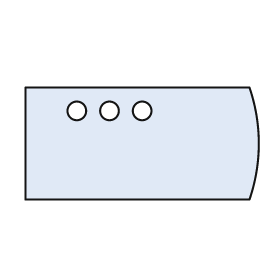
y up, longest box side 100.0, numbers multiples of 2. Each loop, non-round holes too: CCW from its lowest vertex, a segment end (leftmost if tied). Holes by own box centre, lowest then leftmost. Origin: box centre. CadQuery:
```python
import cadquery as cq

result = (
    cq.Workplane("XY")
    .moveTo(-50.0, -24.0)
    .lineTo(46.0, -24.0)
    .threePointArc((50.0, 0.0), (46.0, 24.0))
    .lineTo(-50.0, 24.0)
    .close()
    .moveTo(-28.0, 14.0)
    .circle(4.0)
    .moveTo(-14.0, 14.0)
    .circle(4.0)
    .moveTo(0.0, 14.0)
    .circle(4.0)
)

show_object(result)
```